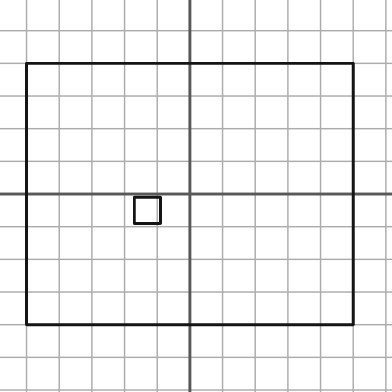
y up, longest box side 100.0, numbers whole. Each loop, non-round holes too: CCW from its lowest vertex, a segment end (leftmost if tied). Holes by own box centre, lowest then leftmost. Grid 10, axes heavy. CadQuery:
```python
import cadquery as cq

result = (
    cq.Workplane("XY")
    .moveTo(-50.0, -40.0)
    .lineTo(50.0, -40.0)
    .lineTo(50.0, 40.0)
    .lineTo(-50.0, 40.0)
    .close()
    .moveTo(-17.0, -9.0)
    .lineTo(-9.0, -9.0)
    .lineTo(-9.0, -1.0)
    .lineTo(-17.0, -1.0)
    .close()
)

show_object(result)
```